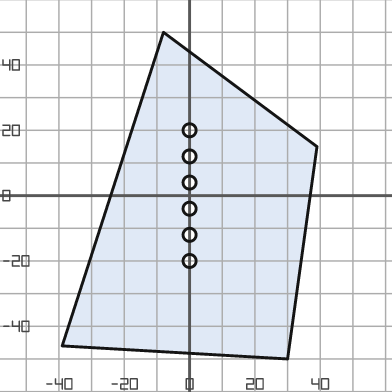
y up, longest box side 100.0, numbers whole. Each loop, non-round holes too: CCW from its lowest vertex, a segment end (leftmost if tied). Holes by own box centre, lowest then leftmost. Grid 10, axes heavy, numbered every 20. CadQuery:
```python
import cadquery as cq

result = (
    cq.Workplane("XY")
    .moveTo(30.0, -50.0)
    .lineTo(39.0, 15.0)
    .lineTo(-8.0, 50.0)
    .lineTo(-39.0, -46.0)
    .close()
    .moveTo(0.0, -20.0)
    .circle(2.0)
    .moveTo(0.0, -12.0)
    .circle(2.0)
    .moveTo(0.0, -4.0)
    .circle(2.0)
    .moveTo(0.0, 4.0)
    .circle(2.0)
    .moveTo(0.0, 12.0)
    .circle(2.0)
    .moveTo(0.0, 20.0)
    .circle(2.0)
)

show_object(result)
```